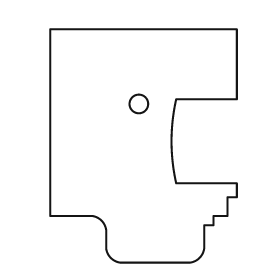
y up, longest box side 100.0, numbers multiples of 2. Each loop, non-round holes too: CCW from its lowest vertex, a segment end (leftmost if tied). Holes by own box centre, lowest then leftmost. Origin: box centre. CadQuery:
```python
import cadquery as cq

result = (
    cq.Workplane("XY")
    .moveTo(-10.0, -50.0)
    .lineTo(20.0, -50.0)
    .threePointArc((24.0, -48.0), (26.0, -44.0))
    .lineTo(26.0, -34.0)
    .lineTo(30.0, -34.0)
    .lineTo(30.0, -30.0)
    .lineTo(36.0, -30.0)
    .lineTo(36.0, -22.0)
    .lineTo(40.0, -22.0)
    .lineTo(40.0, -16.0)
    .lineTo(14.0, -16.0)
    .threePointArc((12.0, 2.0), (14.0, 20.0))
    .lineTo(40.0, 20.0)
    .lineTo(40.0, 50.0)
    .lineTo(-40.0, 50.0)
    .lineTo(-40.0, -30.0)
    .lineTo(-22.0, -30.0)
    .threePointArc((-18.0, -32.0), (-16.0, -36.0))
    .lineTo(-16.0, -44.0)
    .threePointArc((-14.0, -48.0), (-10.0, -50.0))
    .close()
    .moveTo(-2.0, 18.0)
    .circle(4.0)
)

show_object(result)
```